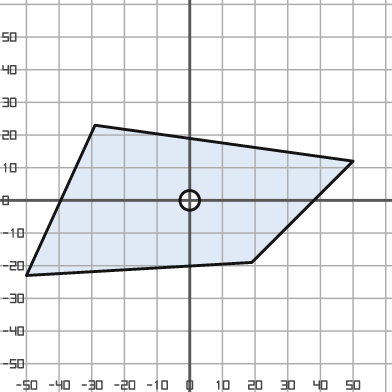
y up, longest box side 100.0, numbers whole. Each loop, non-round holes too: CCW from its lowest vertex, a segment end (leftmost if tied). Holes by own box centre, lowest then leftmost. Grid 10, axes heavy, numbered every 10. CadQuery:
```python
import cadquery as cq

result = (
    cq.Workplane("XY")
    .moveTo(-50.0, -23.0)
    .lineTo(19.0, -19.0)
    .lineTo(50.0, 12.0)
    .lineTo(-29.0, 23.0)
    .close()
    .moveTo(0.0, 0.0)
    .circle(3.0)
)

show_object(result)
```